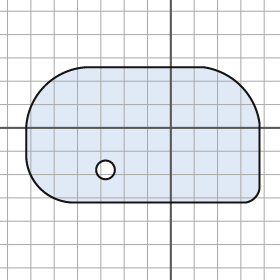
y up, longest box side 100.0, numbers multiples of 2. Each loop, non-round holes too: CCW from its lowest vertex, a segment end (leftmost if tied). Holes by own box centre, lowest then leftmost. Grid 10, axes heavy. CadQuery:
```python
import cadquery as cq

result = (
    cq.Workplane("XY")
    .moveTo(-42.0, -32.0)
    .lineTo(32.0, -32.0)
    .threePointArc((36.0, -30.0), (38.0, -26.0))
    .lineTo(38.0, 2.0)
    .threePointArc((30.0, 18.0), (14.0, 26.0))
    .lineTo(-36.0, 26.0)
    .threePointArc((-54.0, 18.0), (-62.0, 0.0))
    .lineTo(-62.0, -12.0)
    .threePointArc((-56.0, -26.0), (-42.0, -32.0))
    .close()
    .moveTo(-28.0, -18.0)
    .circle(4.0)
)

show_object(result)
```